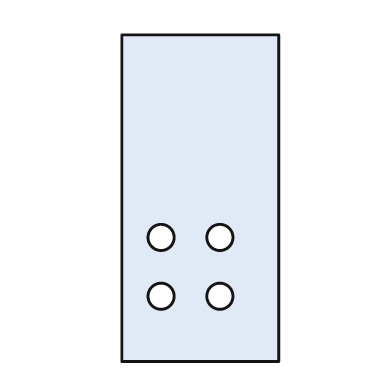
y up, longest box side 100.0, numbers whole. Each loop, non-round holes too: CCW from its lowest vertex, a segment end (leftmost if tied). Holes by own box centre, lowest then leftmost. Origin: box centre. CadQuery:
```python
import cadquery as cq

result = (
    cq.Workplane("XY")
    .moveTo(-24.0, -50.0)
    .lineTo(24.0, -50.0)
    .lineTo(24.0, 50.0)
    .lineTo(-24.0, 50.0)
    .close()
    .moveTo(-12.0, -30.0)
    .circle(4.0)
    .moveTo(6.0, -30.0)
    .circle(4.0)
    .moveTo(-12.0, -12.0)
    .circle(4.0)
    .moveTo(6.0, -12.0)
    .circle(4.0)
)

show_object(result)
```